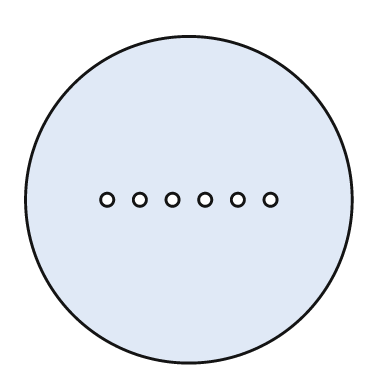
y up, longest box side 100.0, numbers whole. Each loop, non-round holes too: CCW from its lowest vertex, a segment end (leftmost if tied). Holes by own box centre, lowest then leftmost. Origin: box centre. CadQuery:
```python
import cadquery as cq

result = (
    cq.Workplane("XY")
    .moveTo(0.0, 0.0)
    .circle(50.0)
    .moveTo(-25.0, 0.0)
    .circle(2.0)
    .moveTo(-15.0, 0.0)
    .circle(2.0)
    .moveTo(-5.0, 0.0)
    .circle(2.0)
    .moveTo(5.0, 0.0)
    .circle(2.0)
    .moveTo(15.0, 0.0)
    .circle(2.0)
    .moveTo(25.0, 0.0)
    .circle(2.0)
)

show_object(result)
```